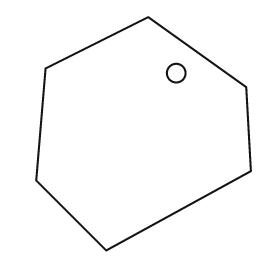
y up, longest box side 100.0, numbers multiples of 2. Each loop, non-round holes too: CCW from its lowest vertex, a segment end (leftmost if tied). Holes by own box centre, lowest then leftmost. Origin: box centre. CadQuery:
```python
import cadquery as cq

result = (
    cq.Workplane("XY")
    .moveTo(-16.0, -50.0)
    .lineTo(46.0, -16.0)
    .lineTo(44.0, 20.0)
    .lineTo(2.0, 50.0)
    .lineTo(-42.0, 28.0)
    .lineTo(-46.0, -20.0)
    .close()
    .moveTo(14.0, 26.0)
    .circle(4.0)
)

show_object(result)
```